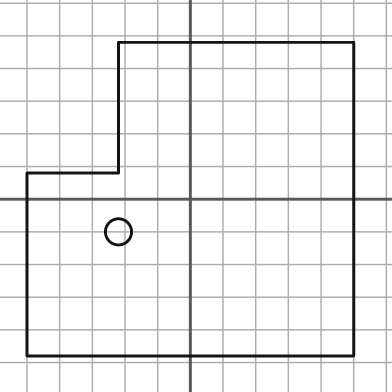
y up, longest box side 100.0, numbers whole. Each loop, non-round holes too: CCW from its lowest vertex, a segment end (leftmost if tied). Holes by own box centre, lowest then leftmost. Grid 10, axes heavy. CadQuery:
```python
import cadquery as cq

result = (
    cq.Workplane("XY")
    .moveTo(-50.0, -48.0)
    .lineTo(50.0, -48.0)
    .lineTo(50.0, 48.0)
    .lineTo(-22.0, 48.0)
    .lineTo(-22.0, 8.0)
    .lineTo(-50.0, 8.0)
    .close()
    .moveTo(-22.0, -10.0)
    .circle(4.0)
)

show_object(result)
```